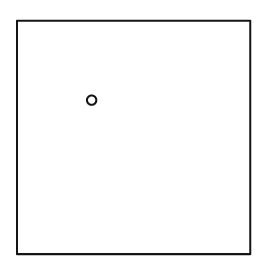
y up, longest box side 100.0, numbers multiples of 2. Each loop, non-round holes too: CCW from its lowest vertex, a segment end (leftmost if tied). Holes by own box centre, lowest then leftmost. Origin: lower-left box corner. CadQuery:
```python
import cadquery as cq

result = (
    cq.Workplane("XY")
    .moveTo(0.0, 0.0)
    .lineTo(100.0, 0.0)
    .lineTo(100.0, 100.0)
    .lineTo(0.0, 100.0)
    .close()
    .moveTo(32.0, 66.0)
    .circle(2.0)
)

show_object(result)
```